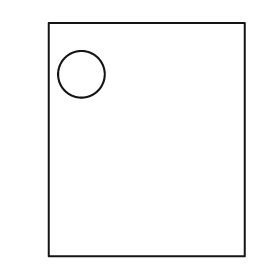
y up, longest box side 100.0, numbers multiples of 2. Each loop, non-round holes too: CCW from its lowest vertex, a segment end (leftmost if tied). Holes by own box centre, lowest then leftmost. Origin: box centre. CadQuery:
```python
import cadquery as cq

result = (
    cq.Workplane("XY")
    .moveTo(-42.0, -50.0)
    .lineTo(42.0, -50.0)
    .lineTo(42.0, 50.0)
    .lineTo(-42.0, 50.0)
    .close()
    .moveTo(-28.0, 28.0)
    .circle(10.0)
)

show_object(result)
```